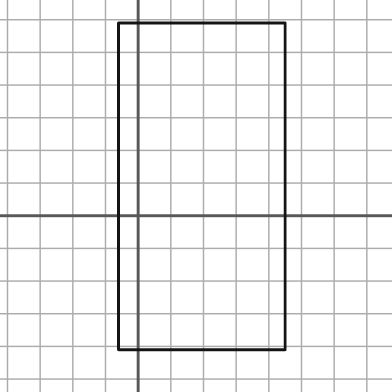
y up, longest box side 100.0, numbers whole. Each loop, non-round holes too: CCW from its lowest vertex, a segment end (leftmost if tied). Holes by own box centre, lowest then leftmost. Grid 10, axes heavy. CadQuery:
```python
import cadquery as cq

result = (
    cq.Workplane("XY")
    .moveTo(-6.0, -41.0)
    .lineTo(45.0, -41.0)
    .lineTo(45.0, 59.0)
    .lineTo(-6.0, 59.0)
    .close()
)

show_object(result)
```